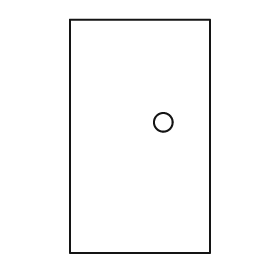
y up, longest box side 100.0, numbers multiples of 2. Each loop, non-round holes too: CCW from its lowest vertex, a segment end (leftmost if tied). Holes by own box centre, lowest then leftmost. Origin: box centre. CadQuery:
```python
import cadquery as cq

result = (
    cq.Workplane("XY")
    .moveTo(-30.0, -50.0)
    .lineTo(30.0, -50.0)
    .lineTo(30.0, 50.0)
    .lineTo(-30.0, 50.0)
    .close()
    .moveTo(10.0, 6.0)
    .circle(4.0)
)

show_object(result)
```